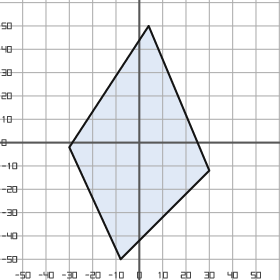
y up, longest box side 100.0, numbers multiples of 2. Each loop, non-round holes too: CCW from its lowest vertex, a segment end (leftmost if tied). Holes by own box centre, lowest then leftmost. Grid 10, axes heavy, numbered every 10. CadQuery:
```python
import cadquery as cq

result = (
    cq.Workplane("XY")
    .moveTo(-8.0, -50.0)
    .lineTo(30.0, -12.0)
    .lineTo(4.0, 50.0)
    .lineTo(-30.0, -2.0)
    .close()
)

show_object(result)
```